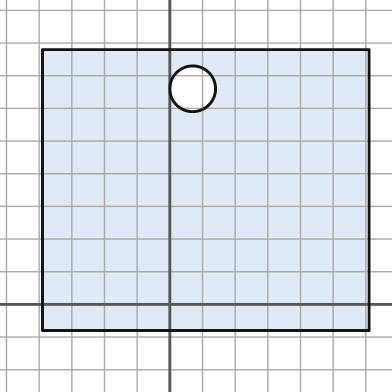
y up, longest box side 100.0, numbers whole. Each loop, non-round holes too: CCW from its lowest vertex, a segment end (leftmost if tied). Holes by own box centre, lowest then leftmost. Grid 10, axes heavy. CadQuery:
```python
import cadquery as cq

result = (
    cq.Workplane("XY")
    .moveTo(-39.0, -8.0)
    .lineTo(61.0, -8.0)
    .lineTo(61.0, 78.0)
    .lineTo(-39.0, 78.0)
    .close()
    .moveTo(7.0, 66.0)
    .circle(7.0)
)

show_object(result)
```